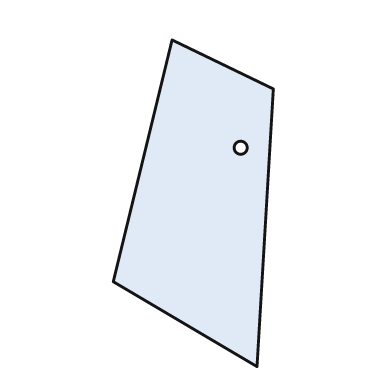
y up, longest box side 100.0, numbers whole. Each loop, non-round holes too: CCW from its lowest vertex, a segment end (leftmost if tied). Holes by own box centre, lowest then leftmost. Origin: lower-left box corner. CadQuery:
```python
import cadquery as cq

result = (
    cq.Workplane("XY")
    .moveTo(44.0, 0.0)
    .lineTo(49.0, 85.0)
    .lineTo(18.0, 100.0)
    .lineTo(0.0, 26.0)
    .close()
    .moveTo(39.0, 67.0)
    .circle(2.0)
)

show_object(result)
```